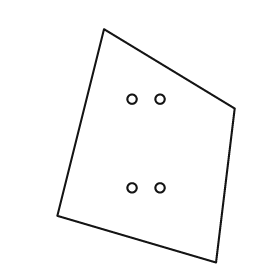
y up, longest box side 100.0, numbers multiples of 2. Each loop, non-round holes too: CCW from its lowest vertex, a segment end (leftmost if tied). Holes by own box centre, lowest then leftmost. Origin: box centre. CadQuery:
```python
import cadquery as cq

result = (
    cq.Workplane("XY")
    .moveTo(30.0, -50.0)
    .lineTo(38.0, 16.0)
    .lineTo(-18.0, 50.0)
    .lineTo(-38.0, -30.0)
    .close()
    .moveTo(-6.0, -18.0)
    .circle(2.0)
    .moveTo(6.0, -18.0)
    .circle(2.0)
    .moveTo(-6.0, 20.0)
    .circle(2.0)
    .moveTo(6.0, 20.0)
    .circle(2.0)
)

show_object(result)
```